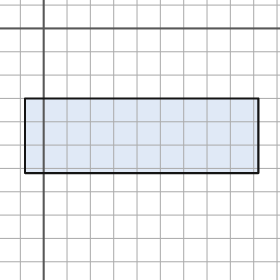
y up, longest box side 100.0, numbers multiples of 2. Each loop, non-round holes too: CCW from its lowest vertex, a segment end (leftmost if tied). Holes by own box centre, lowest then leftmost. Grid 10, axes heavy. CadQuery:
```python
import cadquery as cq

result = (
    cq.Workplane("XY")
    .moveTo(-8.0, -62.0)
    .lineTo(92.0, -62.0)
    .lineTo(92.0, -30.0)
    .lineTo(-8.0, -30.0)
    .close()
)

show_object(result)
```